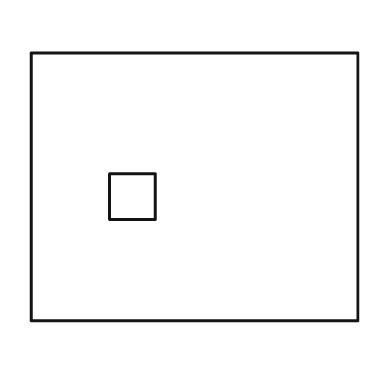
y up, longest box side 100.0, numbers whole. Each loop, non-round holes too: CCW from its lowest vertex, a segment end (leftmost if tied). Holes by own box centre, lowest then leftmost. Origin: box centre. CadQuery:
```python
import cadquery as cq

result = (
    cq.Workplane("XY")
    .moveTo(-50.0, -41.0)
    .lineTo(50.0, -41.0)
    .lineTo(50.0, 41.0)
    .lineTo(-50.0, 41.0)
    .close()
    .moveTo(-26.0, -10.0)
    .lineTo(-12.0, -10.0)
    .lineTo(-12.0, 4.0)
    .lineTo(-26.0, 4.0)
    .close()
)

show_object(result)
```